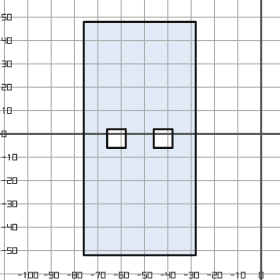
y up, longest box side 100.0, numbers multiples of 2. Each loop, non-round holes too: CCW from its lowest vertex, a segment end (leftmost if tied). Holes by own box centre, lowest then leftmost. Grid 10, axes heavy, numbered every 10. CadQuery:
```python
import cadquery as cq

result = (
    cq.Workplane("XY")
    .moveTo(-76.0, -52.0)
    .lineTo(-28.0, -52.0)
    .lineTo(-28.0, 48.0)
    .lineTo(-76.0, 48.0)
    .close()
    .moveTo(-66.0, -6.0)
    .lineTo(-58.0, -6.0)
    .lineTo(-58.0, 2.0)
    .lineTo(-66.0, 2.0)
    .close()
    .moveTo(-46.0, -6.0)
    .lineTo(-38.0, -6.0)
    .lineTo(-38.0, 2.0)
    .lineTo(-46.0, 2.0)
    .close()
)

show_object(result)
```